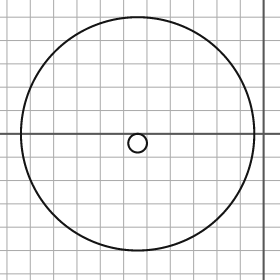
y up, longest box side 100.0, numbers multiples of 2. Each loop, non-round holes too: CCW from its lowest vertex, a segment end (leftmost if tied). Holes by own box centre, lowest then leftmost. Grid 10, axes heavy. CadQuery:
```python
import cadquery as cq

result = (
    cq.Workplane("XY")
    .moveTo(-54.0, 0.0)
    .circle(50.0)
    .moveTo(-54.0, -4.0)
    .circle(4.0)
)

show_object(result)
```